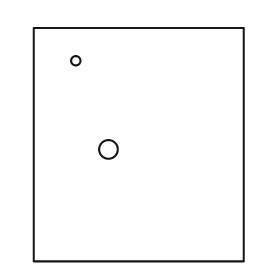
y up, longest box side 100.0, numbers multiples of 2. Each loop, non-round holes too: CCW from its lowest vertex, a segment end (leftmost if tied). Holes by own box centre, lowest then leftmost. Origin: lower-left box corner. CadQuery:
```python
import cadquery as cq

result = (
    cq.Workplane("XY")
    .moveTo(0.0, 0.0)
    .lineTo(90.0, 0.0)
    .lineTo(90.0, 100.0)
    .lineTo(0.0, 100.0)
    .close()
    .moveTo(32.0, 48.0)
    .circle(4.0)
    .moveTo(18.0, 86.0)
    .circle(2.0)
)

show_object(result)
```